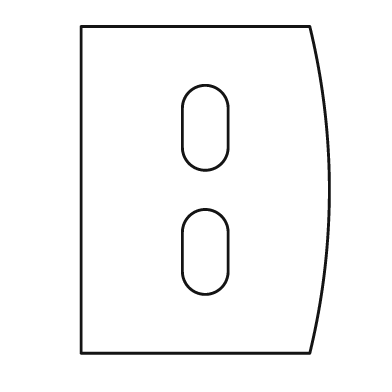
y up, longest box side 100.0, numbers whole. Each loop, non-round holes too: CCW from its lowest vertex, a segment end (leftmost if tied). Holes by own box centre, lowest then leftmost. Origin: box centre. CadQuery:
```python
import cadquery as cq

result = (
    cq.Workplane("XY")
    .moveTo(-38.0, -50.0)
    .lineTo(32.0, -50.0)
    .threePointArc((38.0, 0.0), (32.0, 50.0))
    .lineTo(-38.0, 50.0)
    .close()
    .moveTo(-7.0, -25.0)
    .threePointArc((0.0, -32.0), (7.0, -25.0))
    .lineTo(7.0, -13.0)
    .threePointArc((0.0, -6.0), (-7.0, -13.0))
    .close()
    .moveTo(-7.0, 13.0)
    .threePointArc((0.0, 6.0), (7.0, 13.0))
    .lineTo(7.0, 25.0)
    .threePointArc((0.0, 32.0), (-7.0, 25.0))
    .close()
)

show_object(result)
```